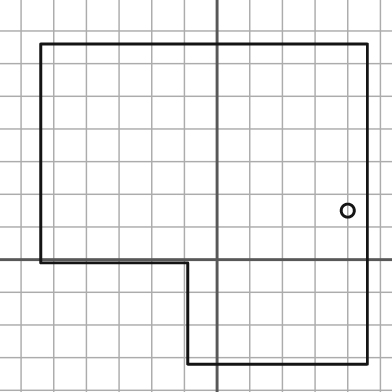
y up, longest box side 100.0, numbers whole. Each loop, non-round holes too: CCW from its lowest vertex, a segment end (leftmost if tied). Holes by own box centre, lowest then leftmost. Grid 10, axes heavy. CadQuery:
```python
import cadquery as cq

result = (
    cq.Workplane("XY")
    .moveTo(-9.0, -32.0)
    .lineTo(46.0, -32.0)
    .lineTo(46.0, 66.0)
    .lineTo(-54.0, 66.0)
    .lineTo(-54.0, -1.0)
    .lineTo(-9.0, -1.0)
    .close()
    .moveTo(40.0, 15.0)
    .circle(2.0)
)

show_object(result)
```